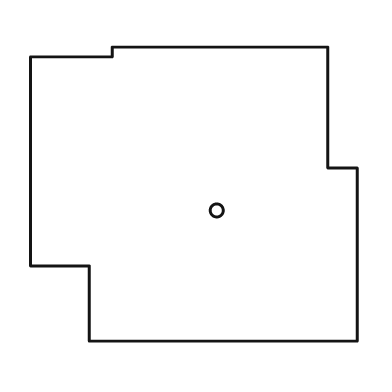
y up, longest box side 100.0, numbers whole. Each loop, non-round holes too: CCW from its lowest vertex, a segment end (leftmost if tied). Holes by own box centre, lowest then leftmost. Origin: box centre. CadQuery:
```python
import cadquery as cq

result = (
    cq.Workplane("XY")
    .moveTo(-32.0, -45.0)
    .lineTo(50.0, -45.0)
    .lineTo(50.0, 8.0)
    .lineTo(41.0, 8.0)
    .lineTo(41.0, 45.0)
    .lineTo(-25.0, 45.0)
    .lineTo(-25.0, 42.0)
    .lineTo(-50.0, 42.0)
    .lineTo(-50.0, -22.0)
    .lineTo(-32.0, -22.0)
    .close()
    .moveTo(7.0, -5.0)
    .circle(2.0)
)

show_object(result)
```